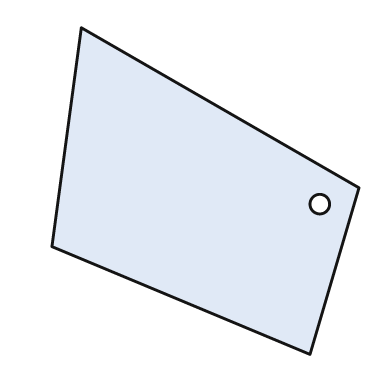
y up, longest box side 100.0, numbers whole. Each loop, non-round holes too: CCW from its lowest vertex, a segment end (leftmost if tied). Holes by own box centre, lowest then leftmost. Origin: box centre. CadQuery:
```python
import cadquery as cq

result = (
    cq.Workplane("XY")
    .moveTo(32.0, -50.0)
    .lineTo(47.0, 1.0)
    .lineTo(-38.0, 50.0)
    .lineTo(-47.0, -17.0)
    .close()
    .moveTo(35.0, -4.0)
    .circle(3.0)
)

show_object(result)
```